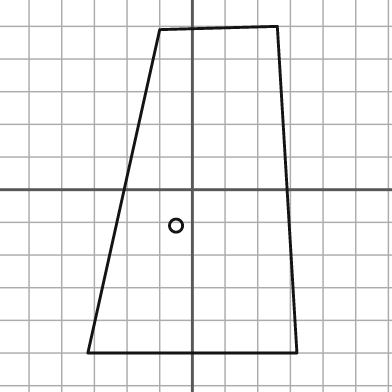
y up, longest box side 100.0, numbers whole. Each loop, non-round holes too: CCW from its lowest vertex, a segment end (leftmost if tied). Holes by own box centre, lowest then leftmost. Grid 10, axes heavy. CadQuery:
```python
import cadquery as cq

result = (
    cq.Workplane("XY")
    .moveTo(-32.0, -50.0)
    .lineTo(32.0, -50.0)
    .lineTo(26.0, 50.0)
    .lineTo(-10.0, 49.0)
    .close()
    .moveTo(-5.0, -11.0)
    .circle(2.0)
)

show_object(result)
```